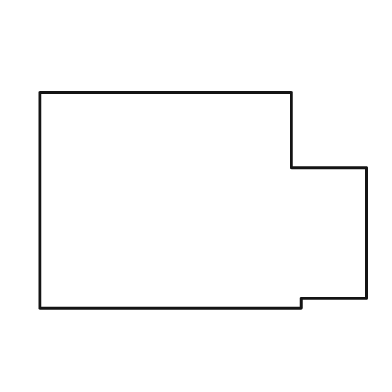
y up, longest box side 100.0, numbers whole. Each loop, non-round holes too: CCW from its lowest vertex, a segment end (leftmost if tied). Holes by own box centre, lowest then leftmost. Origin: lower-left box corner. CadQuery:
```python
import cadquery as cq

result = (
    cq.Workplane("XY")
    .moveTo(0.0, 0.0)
    .lineTo(80.0, 0.0)
    .lineTo(80.0, 3.0)
    .lineTo(100.0, 3.0)
    .lineTo(100.0, 43.0)
    .lineTo(77.0, 43.0)
    .lineTo(77.0, 66.0)
    .lineTo(0.0, 66.0)
    .close()
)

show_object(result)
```